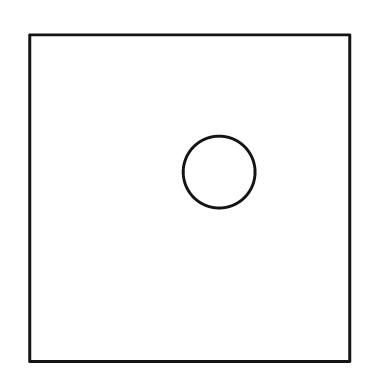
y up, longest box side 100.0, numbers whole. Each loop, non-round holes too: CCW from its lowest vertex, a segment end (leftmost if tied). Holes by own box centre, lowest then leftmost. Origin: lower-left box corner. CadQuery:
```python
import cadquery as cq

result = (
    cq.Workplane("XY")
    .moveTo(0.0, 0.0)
    .lineTo(98.0, 0.0)
    .lineTo(98.0, 100.0)
    .lineTo(0.0, 100.0)
    .close()
    .moveTo(58.0, 58.0)
    .circle(11.0)
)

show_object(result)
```